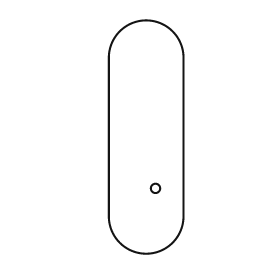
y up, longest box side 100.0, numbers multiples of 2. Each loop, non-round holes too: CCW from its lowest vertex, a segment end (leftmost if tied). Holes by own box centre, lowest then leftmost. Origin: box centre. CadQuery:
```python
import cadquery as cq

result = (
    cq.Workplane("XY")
    .moveTo(-16.0, -34.0)
    .threePointArc((0.0, -50.0), (16.0, -34.0))
    .lineTo(16.0, 34.0)
    .threePointArc((0.0, 50.0), (-16.0, 34.0))
    .close()
    .moveTo(4.0, -22.0)
    .circle(2.0)
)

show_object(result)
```